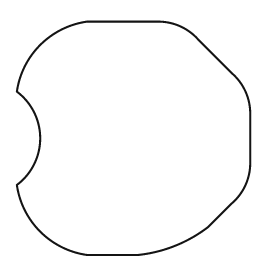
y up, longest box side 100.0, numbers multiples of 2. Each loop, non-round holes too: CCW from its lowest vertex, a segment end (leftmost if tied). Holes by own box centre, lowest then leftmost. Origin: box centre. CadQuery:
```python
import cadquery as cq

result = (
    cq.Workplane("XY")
    .moveTo(-20.0, -50.0)
    .lineTo(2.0, -50.0)
    .threePointArc((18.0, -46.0), (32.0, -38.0))
    .lineTo(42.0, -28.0)
    .threePointArc((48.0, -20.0), (50.0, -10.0))
    .lineTo(50.0, 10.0)
    .threePointArc((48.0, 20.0), (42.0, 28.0))
    .lineTo(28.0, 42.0)
    .threePointArc((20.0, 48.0), (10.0, 50.0))
    .lineTo(-20.0, 50.0)
    .threePointArc((-40.0, 40.0), (-50.0, 20.0))
    .threePointArc((-40.0, 0.0), (-50.0, -20.0))
    .threePointArc((-40.0, -40.0), (-20.0, -50.0))
    .close()
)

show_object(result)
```